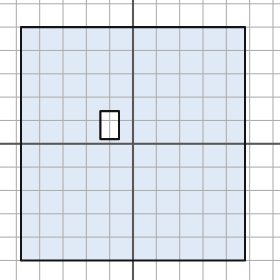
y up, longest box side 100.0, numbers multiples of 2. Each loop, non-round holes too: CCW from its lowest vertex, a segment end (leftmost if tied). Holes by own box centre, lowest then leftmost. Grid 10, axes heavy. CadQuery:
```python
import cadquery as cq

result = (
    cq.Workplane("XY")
    .moveTo(-48.0, -50.0)
    .lineTo(48.0, -50.0)
    .lineTo(48.0, 50.0)
    .lineTo(-48.0, 50.0)
    .close()
    .moveTo(-14.0, 2.0)
    .lineTo(-6.0, 2.0)
    .lineTo(-6.0, 14.0)
    .lineTo(-14.0, 14.0)
    .close()
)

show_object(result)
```